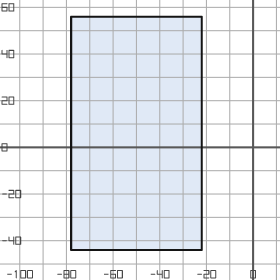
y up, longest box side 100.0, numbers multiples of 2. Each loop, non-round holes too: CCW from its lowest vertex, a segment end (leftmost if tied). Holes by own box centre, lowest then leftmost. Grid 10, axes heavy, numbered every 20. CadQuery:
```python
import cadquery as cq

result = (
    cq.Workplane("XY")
    .moveTo(-78.0, -44.0)
    .lineTo(-22.0, -44.0)
    .lineTo(-22.0, 56.0)
    .lineTo(-78.0, 56.0)
    .close()
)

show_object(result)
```